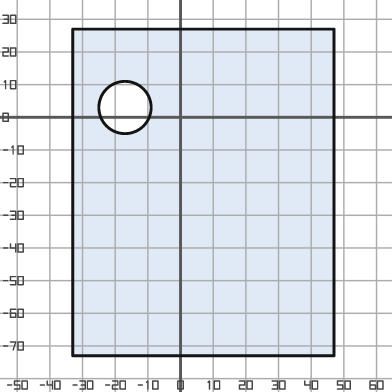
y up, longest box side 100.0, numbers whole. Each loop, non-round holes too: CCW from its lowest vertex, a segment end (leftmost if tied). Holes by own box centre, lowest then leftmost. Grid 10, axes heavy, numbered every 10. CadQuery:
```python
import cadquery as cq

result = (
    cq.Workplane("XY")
    .moveTo(-33.0, -73.0)
    .lineTo(47.0, -73.0)
    .lineTo(47.0, 27.0)
    .lineTo(-33.0, 27.0)
    .close()
    .moveTo(-17.0, 3.0)
    .circle(8.0)
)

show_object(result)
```